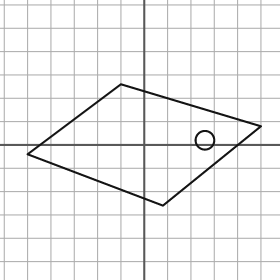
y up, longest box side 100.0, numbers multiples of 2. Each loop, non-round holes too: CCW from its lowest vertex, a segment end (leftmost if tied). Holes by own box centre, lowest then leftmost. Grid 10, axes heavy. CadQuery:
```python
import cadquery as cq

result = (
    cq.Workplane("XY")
    .moveTo(8.0, -26.0)
    .lineTo(50.0, 8.0)
    .lineTo(-10.0, 26.0)
    .lineTo(-50.0, -4.0)
    .close()
    .moveTo(26.0, 2.0)
    .circle(4.0)
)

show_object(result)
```